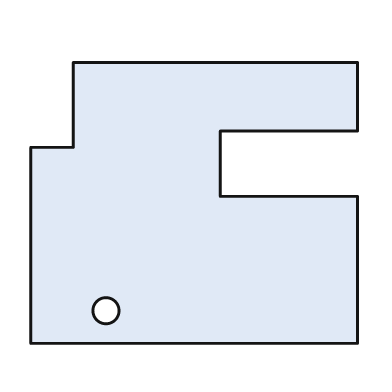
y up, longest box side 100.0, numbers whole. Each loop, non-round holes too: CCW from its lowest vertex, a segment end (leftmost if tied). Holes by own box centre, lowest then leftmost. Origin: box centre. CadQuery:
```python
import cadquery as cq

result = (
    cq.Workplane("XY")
    .moveTo(-50.0, -43.0)
    .lineTo(50.0, -43.0)
    .lineTo(50.0, 2.0)
    .lineTo(8.0, 2.0)
    .lineTo(8.0, 22.0)
    .lineTo(50.0, 22.0)
    .lineTo(50.0, 43.0)
    .lineTo(-37.0, 43.0)
    .lineTo(-37.0, 17.0)
    .lineTo(-50.0, 17.0)
    .close()
    .moveTo(-27.0, -33.0)
    .circle(4.0)
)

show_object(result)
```